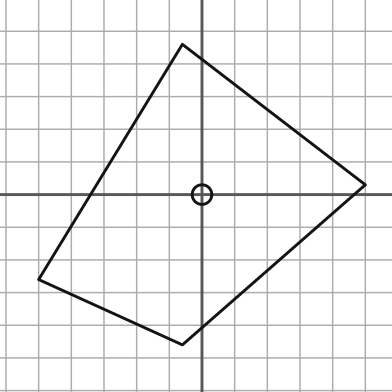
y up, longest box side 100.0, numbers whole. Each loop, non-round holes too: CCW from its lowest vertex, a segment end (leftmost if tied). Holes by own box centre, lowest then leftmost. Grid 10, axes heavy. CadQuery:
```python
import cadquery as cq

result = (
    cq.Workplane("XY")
    .moveTo(-6.0, -46.0)
    .lineTo(50.0, 3.0)
    .lineTo(-6.0, 46.0)
    .lineTo(-50.0, -26.0)
    .close()
    .moveTo(0.0, 0.0)
    .circle(3.0)
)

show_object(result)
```